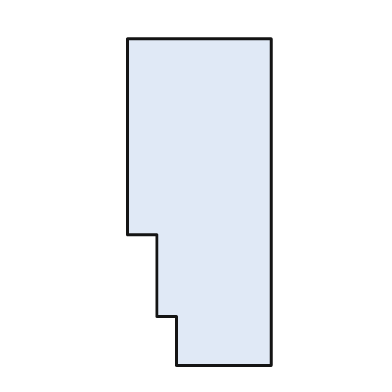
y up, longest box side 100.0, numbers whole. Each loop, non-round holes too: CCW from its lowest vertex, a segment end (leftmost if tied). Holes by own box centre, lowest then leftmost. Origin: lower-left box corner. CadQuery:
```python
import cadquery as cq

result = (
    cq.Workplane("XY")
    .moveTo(15.0, 0.0)
    .lineTo(44.0, 0.0)
    .lineTo(44.0, 100.0)
    .lineTo(0.0, 100.0)
    .lineTo(0.0, 40.0)
    .lineTo(9.0, 40.0)
    .lineTo(9.0, 15.0)
    .lineTo(15.0, 15.0)
    .close()
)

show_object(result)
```